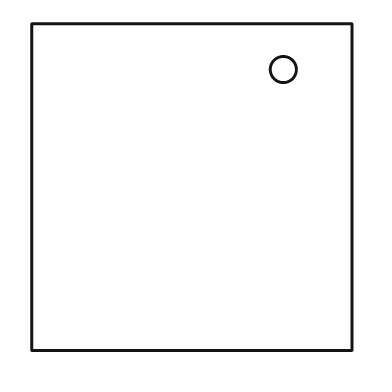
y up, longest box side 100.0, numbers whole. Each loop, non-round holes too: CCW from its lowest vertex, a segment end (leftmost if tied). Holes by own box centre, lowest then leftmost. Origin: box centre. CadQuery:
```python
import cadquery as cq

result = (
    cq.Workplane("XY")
    .moveTo(-49.0, -50.0)
    .lineTo(49.0, -50.0)
    .lineTo(49.0, 50.0)
    .lineTo(-49.0, 50.0)
    .close()
    .moveTo(28.0, 36.0)
    .circle(4.0)
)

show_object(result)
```